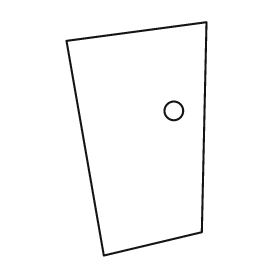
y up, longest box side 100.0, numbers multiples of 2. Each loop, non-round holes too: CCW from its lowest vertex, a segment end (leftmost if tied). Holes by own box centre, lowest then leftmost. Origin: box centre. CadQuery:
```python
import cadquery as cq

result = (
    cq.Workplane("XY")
    .moveTo(-14.0, -50.0)
    .lineTo(28.0, -40.0)
    .lineTo(30.0, 50.0)
    .lineTo(-30.0, 42.0)
    .close()
    .moveTo(16.0, 12.0)
    .circle(4.0)
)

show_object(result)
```